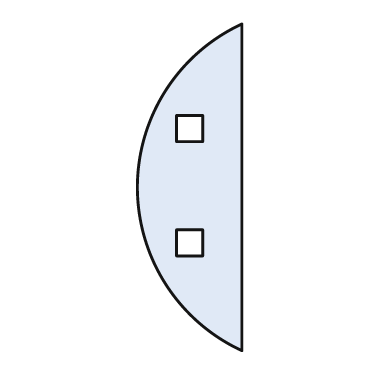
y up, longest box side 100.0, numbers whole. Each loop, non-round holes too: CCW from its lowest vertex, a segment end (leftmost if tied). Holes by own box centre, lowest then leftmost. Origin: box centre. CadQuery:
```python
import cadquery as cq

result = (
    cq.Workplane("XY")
    .moveTo(16.0, -50.0)
    .lineTo(16.0, 50.0)
    .threePointArc((-16.0, 0.0), (16.0, -50.0))
    .close()
    .moveTo(-4.0, -21.0)
    .lineTo(4.0, -21.0)
    .lineTo(4.0, -13.0)
    .lineTo(-4.0, -13.0)
    .close()
    .moveTo(-4.0, 14.0)
    .lineTo(4.0, 14.0)
    .lineTo(4.0, 22.0)
    .lineTo(-4.0, 22.0)
    .close()
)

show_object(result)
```